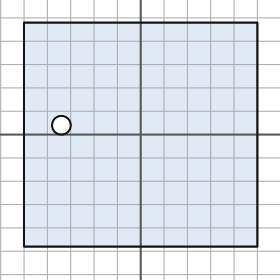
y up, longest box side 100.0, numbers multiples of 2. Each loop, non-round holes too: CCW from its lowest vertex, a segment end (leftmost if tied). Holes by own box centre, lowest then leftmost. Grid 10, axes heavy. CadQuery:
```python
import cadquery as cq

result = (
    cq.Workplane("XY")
    .moveTo(-50.0, -48.0)
    .lineTo(50.0, -48.0)
    .lineTo(50.0, 48.0)
    .lineTo(-50.0, 48.0)
    .close()
    .moveTo(-34.0, 4.0)
    .circle(4.0)
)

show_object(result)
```